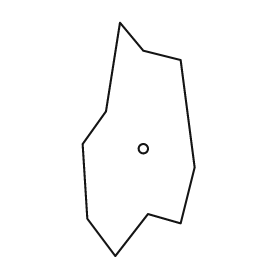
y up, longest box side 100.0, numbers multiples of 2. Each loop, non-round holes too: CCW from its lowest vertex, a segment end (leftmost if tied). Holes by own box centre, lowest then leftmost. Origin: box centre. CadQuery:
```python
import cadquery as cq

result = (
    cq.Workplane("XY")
    .moveTo(-10.0, -50.0)
    .lineTo(4.0, -32.0)
    .lineTo(18.0, -36.0)
    .lineTo(24.0, -12.0)
    .lineTo(18.0, 34.0)
    .lineTo(2.0, 38.0)
    .lineTo(-8.0, 50.0)
    .lineTo(-14.0, 12.0)
    .lineTo(-24.0, -2.0)
    .lineTo(-22.0, -34.0)
    .close()
    .moveTo(2.0, -4.0)
    .circle(2.0)
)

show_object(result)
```